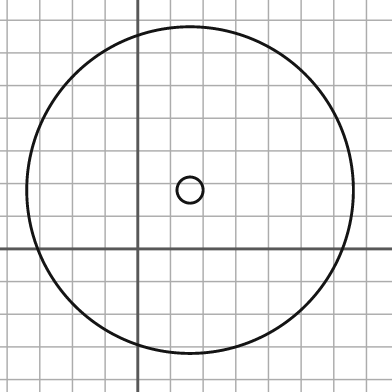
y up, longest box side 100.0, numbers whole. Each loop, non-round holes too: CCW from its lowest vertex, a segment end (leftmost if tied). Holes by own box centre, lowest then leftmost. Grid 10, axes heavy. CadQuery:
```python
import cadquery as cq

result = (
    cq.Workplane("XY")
    .moveTo(16.0, 18.0)
    .circle(50.0)
    .moveTo(16.0, 18.0)
    .circle(4.0)
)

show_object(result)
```